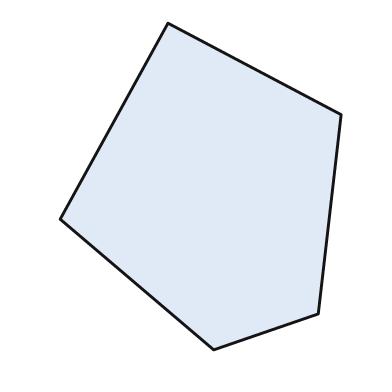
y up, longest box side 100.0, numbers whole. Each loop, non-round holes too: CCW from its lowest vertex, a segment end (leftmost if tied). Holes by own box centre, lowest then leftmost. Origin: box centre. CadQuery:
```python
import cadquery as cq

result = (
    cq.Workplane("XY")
    .moveTo(4.0, -50.0)
    .lineTo(36.0, -39.0)
    .lineTo(43.0, 22.0)
    .lineTo(-10.0, 50.0)
    .lineTo(-43.0, -10.0)
    .close()
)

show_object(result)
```